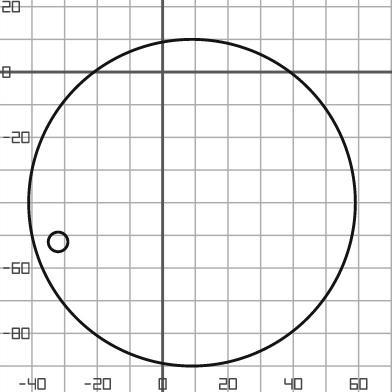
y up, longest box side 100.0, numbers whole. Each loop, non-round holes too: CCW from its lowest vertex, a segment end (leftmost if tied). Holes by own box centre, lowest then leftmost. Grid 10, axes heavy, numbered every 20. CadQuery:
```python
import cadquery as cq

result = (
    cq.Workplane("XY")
    .moveTo(9.0, -40.0)
    .circle(50.0)
    .moveTo(-32.0, -52.0)
    .circle(3.0)
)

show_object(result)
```